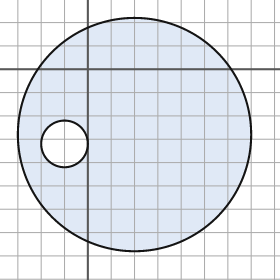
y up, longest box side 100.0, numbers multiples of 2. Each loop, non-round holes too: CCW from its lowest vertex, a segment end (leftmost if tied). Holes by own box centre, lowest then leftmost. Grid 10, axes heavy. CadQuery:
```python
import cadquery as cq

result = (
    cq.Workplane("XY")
    .moveTo(20.0, -28.0)
    .circle(50.0)
    .moveTo(-10.0, -32.0)
    .circle(10.0)
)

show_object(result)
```